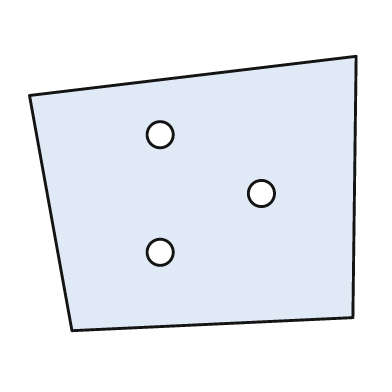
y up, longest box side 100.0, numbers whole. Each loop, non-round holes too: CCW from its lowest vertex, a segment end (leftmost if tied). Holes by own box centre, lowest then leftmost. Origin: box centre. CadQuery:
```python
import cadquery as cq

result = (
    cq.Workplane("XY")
    .moveTo(-37.0, -42.0)
    .lineTo(49.0, -38.0)
    .lineTo(50.0, 42.0)
    .lineTo(-50.0, 30.0)
    .close()
    .moveTo(-10.0, -18.0)
    .circle(4.0)
    .moveTo(21.0, 0.0)
    .circle(4.0)
    .moveTo(-10.0, 18.0)
    .circle(4.0)
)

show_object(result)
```